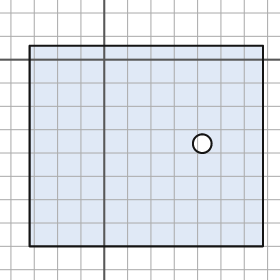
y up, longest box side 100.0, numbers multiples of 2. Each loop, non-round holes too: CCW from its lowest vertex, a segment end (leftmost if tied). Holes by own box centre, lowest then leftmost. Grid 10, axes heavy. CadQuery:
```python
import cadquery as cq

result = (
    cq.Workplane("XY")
    .moveTo(-32.0, -80.0)
    .lineTo(68.0, -80.0)
    .lineTo(68.0, 6.0)
    .lineTo(-32.0, 6.0)
    .close()
    .moveTo(42.0, -36.0)
    .circle(4.0)
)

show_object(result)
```